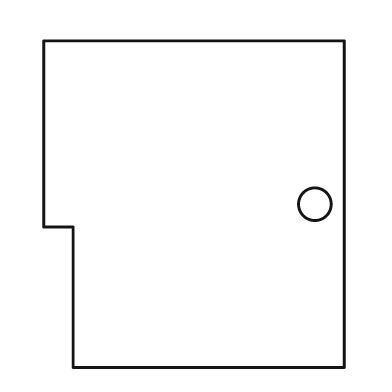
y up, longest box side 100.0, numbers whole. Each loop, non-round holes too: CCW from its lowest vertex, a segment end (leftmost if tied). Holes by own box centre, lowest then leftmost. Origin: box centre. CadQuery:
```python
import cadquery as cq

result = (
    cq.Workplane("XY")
    .moveTo(-37.0, -50.0)
    .lineTo(46.0, -50.0)
    .lineTo(46.0, 50.0)
    .lineTo(-46.0, 50.0)
    .lineTo(-46.0, -7.0)
    .lineTo(-37.0, -7.0)
    .close()
    .moveTo(37.0, 0.0)
    .circle(5.0)
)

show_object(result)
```